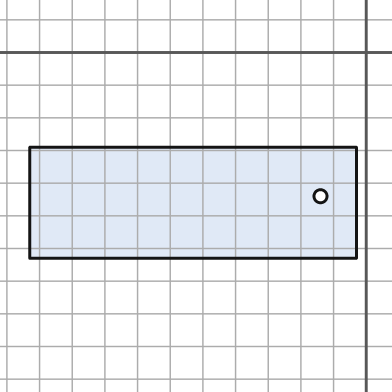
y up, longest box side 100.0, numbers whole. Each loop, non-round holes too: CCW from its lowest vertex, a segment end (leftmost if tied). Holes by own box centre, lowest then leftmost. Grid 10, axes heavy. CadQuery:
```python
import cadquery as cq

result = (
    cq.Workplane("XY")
    .moveTo(-103.0, -63.0)
    .lineTo(-3.0, -63.0)
    .lineTo(-3.0, -29.0)
    .lineTo(-103.0, -29.0)
    .close()
    .moveTo(-14.0, -44.0)
    .circle(2.0)
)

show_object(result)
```